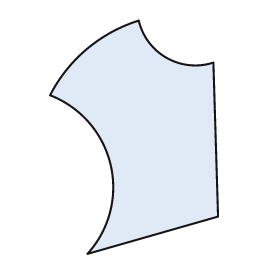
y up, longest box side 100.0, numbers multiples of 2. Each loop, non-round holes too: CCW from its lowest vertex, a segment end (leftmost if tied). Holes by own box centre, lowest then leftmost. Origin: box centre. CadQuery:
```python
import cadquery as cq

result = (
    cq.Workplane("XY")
    .moveTo(-20.0, -50.0)
    .lineTo(36.0, -34.0)
    .lineTo(34.0, 32.0)
    .threePointArc((14.0, 34.0), (2.0, 50.0))
    .threePointArc((-20.0, 38.0), (-36.0, 18.0))
    .threePointArc((-10.0, -12.0), (-20.0, -50.0))
    .close()
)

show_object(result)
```